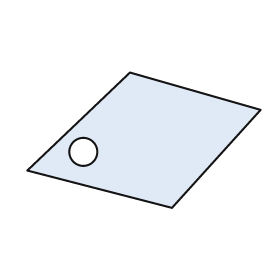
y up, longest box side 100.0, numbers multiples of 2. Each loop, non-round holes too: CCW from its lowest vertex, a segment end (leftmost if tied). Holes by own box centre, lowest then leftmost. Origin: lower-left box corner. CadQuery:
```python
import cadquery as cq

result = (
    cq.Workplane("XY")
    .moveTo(62.0, 0.0)
    .lineTo(100.0, 42.0)
    .lineTo(44.0, 58.0)
    .lineTo(0.0, 16.0)
    .close()
    .moveTo(24.0, 24.0)
    .circle(6.0)
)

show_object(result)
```